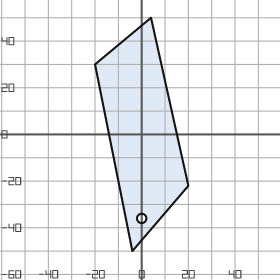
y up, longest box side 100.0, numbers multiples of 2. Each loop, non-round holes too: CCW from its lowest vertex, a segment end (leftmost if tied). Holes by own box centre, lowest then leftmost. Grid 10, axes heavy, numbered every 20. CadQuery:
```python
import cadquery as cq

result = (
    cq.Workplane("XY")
    .moveTo(-4.0, -50.0)
    .lineTo(20.0, -22.0)
    .lineTo(4.0, 50.0)
    .lineTo(-20.0, 30.0)
    .close()
    .moveTo(0.0, -36.0)
    .circle(2.0)
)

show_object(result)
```